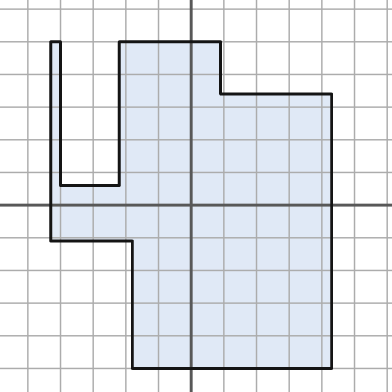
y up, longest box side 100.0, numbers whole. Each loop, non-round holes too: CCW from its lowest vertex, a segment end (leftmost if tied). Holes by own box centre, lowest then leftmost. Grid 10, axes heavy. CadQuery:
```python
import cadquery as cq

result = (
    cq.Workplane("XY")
    .moveTo(-18.0, -50.0)
    .lineTo(43.0, -50.0)
    .lineTo(43.0, 34.0)
    .lineTo(9.0, 34.0)
    .lineTo(9.0, 50.0)
    .lineTo(-22.0, 50.0)
    .lineTo(-22.0, 6.0)
    .lineTo(-40.0, 6.0)
    .lineTo(-40.0, 50.0)
    .lineTo(-43.0, 50.0)
    .lineTo(-43.0, -11.0)
    .lineTo(-18.0, -11.0)
    .close()
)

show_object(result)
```